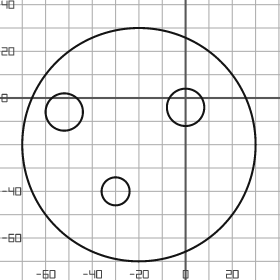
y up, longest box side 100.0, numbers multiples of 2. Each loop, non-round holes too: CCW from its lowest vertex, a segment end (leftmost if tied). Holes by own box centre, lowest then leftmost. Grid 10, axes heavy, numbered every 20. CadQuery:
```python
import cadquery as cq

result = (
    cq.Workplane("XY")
    .moveTo(-20.0, -20.0)
    .circle(50.0)
    .moveTo(-30.0, -40.0)
    .circle(6.0)
    .moveTo(-52.0, -6.0)
    .circle(8.0)
    .moveTo(0.0, -4.0)
    .circle(8.0)
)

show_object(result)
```